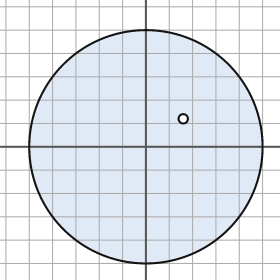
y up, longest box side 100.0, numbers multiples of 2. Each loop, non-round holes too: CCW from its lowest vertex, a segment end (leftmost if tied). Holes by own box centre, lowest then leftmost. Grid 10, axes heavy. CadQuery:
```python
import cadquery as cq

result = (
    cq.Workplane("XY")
    .moveTo(0.0, 0.0)
    .circle(50.0)
    .moveTo(16.0, 12.0)
    .circle(2.0)
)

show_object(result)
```